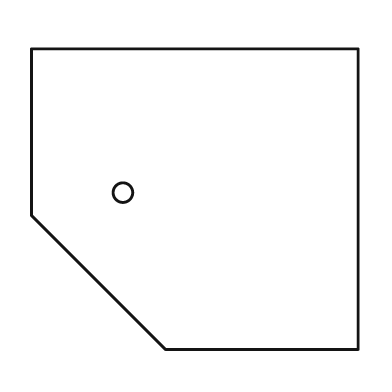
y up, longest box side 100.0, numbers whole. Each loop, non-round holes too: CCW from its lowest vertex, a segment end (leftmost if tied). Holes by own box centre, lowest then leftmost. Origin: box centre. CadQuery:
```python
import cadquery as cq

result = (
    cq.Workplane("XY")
    .moveTo(-9.0, -46.0)
    .lineTo(50.0, -46.0)
    .lineTo(50.0, 46.0)
    .lineTo(-50.0, 46.0)
    .lineTo(-50.0, -5.0)
    .close()
    .moveTo(-22.0, 2.0)
    .circle(3.0)
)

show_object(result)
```